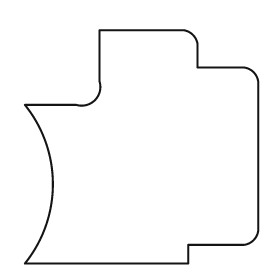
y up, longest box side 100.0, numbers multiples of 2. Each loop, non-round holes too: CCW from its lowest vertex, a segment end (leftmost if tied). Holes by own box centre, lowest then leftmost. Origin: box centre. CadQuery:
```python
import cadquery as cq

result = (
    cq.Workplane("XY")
    .moveTo(-50.0, -50.0)
    .lineTo(20.0, -50.0)
    .lineTo(20.0, -42.0)
    .lineTo(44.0, -42.0)
    .threePointArc((48.0, -40.0), (50.0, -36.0))
    .lineTo(50.0, 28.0)
    .threePointArc((48.0, 32.0), (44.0, 34.0))
    .lineTo(24.0, 34.0)
    .lineTo(24.0, 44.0)
    .threePointArc((22.0, 48.0), (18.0, 50.0))
    .lineTo(-18.0, 50.0)
    .lineTo(-18.0, 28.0)
    .threePointArc((-20.0, 20.0), (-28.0, 18.0))
    .lineTo(-50.0, 18.0)
    .threePointArc((-38.0, -16.0), (-50.0, -50.0))
    .close()
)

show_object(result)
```